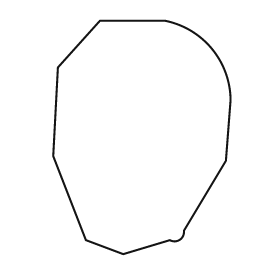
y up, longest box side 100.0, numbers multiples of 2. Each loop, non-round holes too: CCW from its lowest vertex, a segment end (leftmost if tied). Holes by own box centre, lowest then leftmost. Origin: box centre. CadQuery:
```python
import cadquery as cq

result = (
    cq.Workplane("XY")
    .moveTo(-8.0, -50.0)
    .lineTo(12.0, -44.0)
    .threePointArc((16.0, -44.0), (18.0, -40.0))
    .lineTo(36.0, -10.0)
    .lineTo(38.0, 16.0)
    .threePointArc((30.0, 38.0), (10.0, 50.0))
    .lineTo(-18.0, 50.0)
    .lineTo(-36.0, 30.0)
    .lineTo(-38.0, -8.0)
    .lineTo(-24.0, -44.0)
    .close()
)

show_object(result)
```